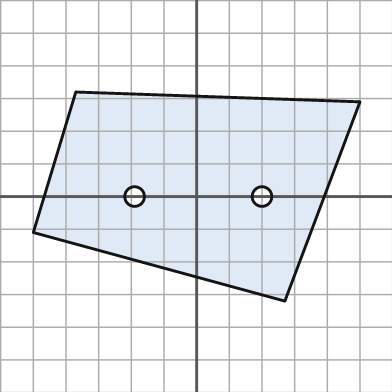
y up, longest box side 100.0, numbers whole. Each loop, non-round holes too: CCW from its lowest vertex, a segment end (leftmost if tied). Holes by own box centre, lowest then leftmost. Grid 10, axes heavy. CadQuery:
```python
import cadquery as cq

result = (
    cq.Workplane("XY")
    .moveTo(27.0, -32.0)
    .lineTo(50.0, 29.0)
    .lineTo(-37.0, 32.0)
    .lineTo(-50.0, -11.0)
    .close()
    .moveTo(-19.0, 0.0)
    .circle(3.0)
    .moveTo(20.0, 0.0)
    .circle(3.0)
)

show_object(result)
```